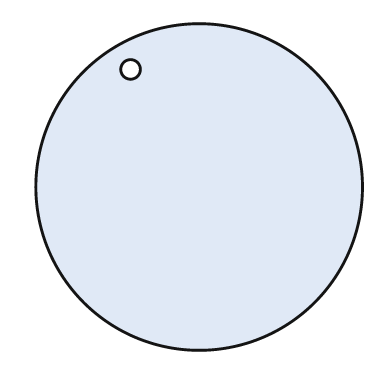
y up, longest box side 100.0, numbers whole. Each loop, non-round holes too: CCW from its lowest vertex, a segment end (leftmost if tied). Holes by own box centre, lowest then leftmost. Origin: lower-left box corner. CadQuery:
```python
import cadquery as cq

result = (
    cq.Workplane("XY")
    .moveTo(50.0, 50.0)
    .circle(50.0)
    .moveTo(29.0, 86.0)
    .circle(3.0)
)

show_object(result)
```